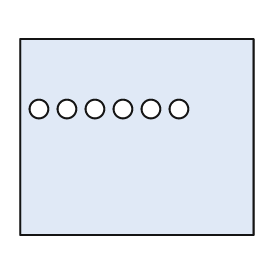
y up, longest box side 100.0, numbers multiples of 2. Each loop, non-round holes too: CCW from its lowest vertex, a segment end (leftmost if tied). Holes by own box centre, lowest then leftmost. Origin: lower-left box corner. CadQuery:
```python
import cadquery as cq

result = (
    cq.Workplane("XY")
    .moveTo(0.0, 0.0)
    .lineTo(100.0, 0.0)
    .lineTo(100.0, 84.0)
    .lineTo(0.0, 84.0)
    .close()
    .moveTo(8.0, 54.0)
    .circle(4.0)
    .moveTo(20.0, 54.0)
    .circle(4.0)
    .moveTo(32.0, 54.0)
    .circle(4.0)
    .moveTo(44.0, 54.0)
    .circle(4.0)
    .moveTo(56.0, 54.0)
    .circle(4.0)
    .moveTo(68.0, 54.0)
    .circle(4.0)
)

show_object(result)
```